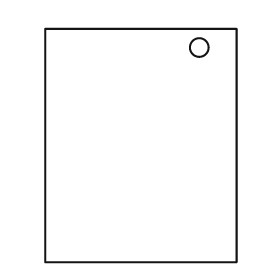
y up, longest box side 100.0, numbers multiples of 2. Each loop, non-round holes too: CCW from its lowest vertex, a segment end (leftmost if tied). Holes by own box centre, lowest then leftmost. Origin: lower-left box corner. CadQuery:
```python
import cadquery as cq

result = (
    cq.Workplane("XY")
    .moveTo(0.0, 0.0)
    .lineTo(82.0, 0.0)
    .lineTo(82.0, 100.0)
    .lineTo(0.0, 100.0)
    .close()
    .moveTo(66.0, 92.0)
    .circle(4.0)
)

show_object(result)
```